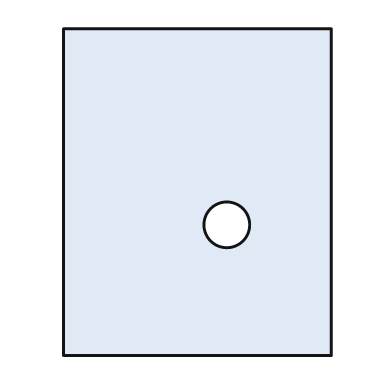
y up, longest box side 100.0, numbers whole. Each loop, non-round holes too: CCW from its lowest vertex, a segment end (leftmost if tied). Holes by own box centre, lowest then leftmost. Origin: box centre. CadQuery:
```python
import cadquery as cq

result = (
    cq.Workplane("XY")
    .moveTo(-41.0, -50.0)
    .lineTo(41.0, -50.0)
    .lineTo(41.0, 50.0)
    .lineTo(-41.0, 50.0)
    .close()
    .moveTo(9.0, -10.0)
    .circle(7.0)
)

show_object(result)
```